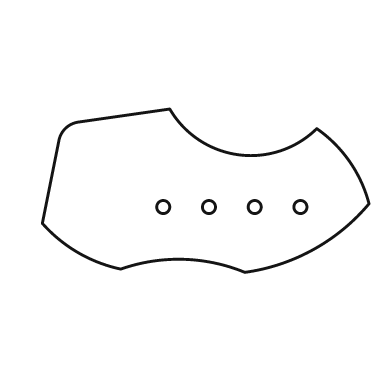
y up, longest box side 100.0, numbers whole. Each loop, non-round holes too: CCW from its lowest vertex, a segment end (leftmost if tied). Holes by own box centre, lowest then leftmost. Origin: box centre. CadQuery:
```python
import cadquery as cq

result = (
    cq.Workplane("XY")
    .moveTo(12.0, -25.0)
    .threePointArc((33.0, -18.0), (50.0, -4.0))
    .threePointArc((44.0, 9.0), (34.0, 19.0))
    .threePointArc((10.0, 11.0), (-11.0, 25.0))
    .lineTo(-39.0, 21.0)
    .threePointArc((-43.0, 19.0), (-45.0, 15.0))
    .lineTo(-50.0, -10.0)
    .threePointArc((-39.0, -19.0), (-26.0, -24.0))
    .threePointArc((-7.0, -21.0), (12.0, -25.0))
    .close()
    .moveTo(-13.0, -5.0)
    .circle(2.0)
    .moveTo(1.0, -5.0)
    .circle(2.0)
    .moveTo(15.0, -5.0)
    .circle(2.0)
    .moveTo(29.0, -5.0)
    .circle(2.0)
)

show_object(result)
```